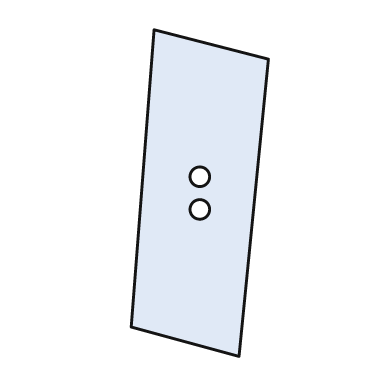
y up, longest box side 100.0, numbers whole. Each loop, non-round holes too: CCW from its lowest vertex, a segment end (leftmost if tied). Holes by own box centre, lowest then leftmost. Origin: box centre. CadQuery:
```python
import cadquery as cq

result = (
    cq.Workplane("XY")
    .moveTo(12.0, -50.0)
    .lineTo(21.0, 41.0)
    .lineTo(-14.0, 50.0)
    .lineTo(-21.0, -41.0)
    .close()
    .moveTo(0.0, -5.0)
    .circle(3.0)
    .moveTo(0.0, 5.0)
    .circle(3.0)
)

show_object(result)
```